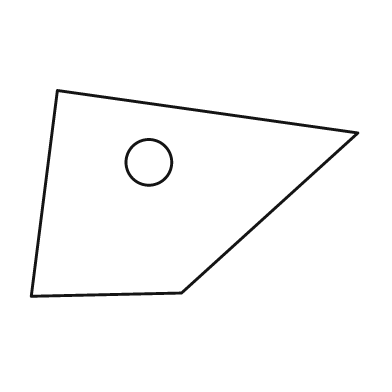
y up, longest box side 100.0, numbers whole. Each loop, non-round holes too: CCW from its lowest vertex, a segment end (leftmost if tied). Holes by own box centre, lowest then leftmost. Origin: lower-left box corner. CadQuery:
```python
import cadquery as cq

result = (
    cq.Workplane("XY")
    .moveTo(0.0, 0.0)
    .lineTo(46.0, 1.0)
    .lineTo(100.0, 50.0)
    .lineTo(8.0, 63.0)
    .close()
    .moveTo(36.0, 41.0)
    .circle(7.0)
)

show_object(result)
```